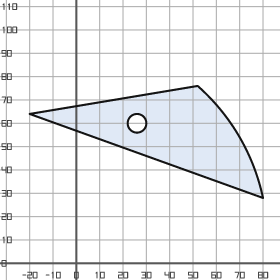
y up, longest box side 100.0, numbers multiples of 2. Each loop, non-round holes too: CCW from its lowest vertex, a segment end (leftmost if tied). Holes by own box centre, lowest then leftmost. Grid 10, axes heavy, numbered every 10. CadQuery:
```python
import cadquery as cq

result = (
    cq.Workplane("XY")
    .moveTo(80.0, 28.0)
    .threePointArc((70.0, 54.0), (52.0, 76.0))
    .lineTo(-20.0, 64.0)
    .close()
    .moveTo(26.0, 60.0)
    .circle(4.0)
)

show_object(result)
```